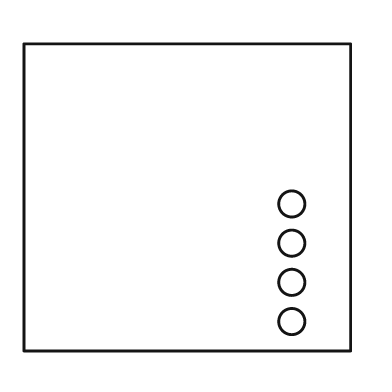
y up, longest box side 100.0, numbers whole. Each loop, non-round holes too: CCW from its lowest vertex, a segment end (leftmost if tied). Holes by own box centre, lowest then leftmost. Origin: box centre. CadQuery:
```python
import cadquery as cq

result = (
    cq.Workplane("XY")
    .moveTo(-50.0, -47.0)
    .lineTo(50.0, -47.0)
    .lineTo(50.0, 47.0)
    .lineTo(-50.0, 47.0)
    .close()
    .moveTo(32.0, -38.0)
    .circle(4.0)
    .moveTo(32.0, -26.0)
    .circle(4.0)
    .moveTo(32.0, -14.0)
    .circle(4.0)
    .moveTo(32.0, -2.0)
    .circle(4.0)
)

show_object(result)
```